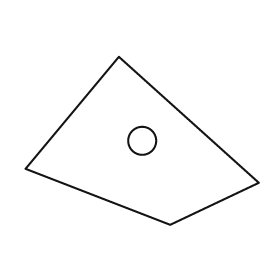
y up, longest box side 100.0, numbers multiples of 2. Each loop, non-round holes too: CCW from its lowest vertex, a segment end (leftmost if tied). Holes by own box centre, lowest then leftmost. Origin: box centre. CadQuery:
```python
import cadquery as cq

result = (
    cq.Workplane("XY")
    .moveTo(12.0, -36.0)
    .lineTo(50.0, -18.0)
    .lineTo(-10.0, 36.0)
    .lineTo(-50.0, -12.0)
    .close()
    .moveTo(0.0, 0.0)
    .circle(6.0)
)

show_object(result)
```